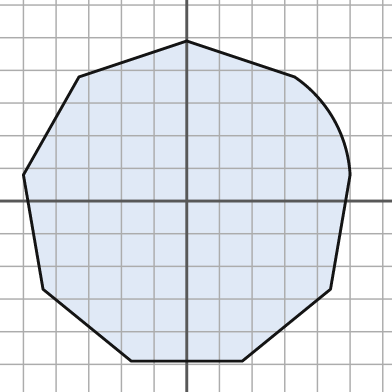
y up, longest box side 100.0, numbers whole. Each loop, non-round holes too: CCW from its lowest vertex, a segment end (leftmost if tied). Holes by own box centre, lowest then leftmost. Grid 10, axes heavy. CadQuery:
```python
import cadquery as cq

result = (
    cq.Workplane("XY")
    .moveTo(-17.0, -49.0)
    .lineTo(17.0, -49.0)
    .lineTo(44.0, -27.0)
    .lineTo(50.0, 8.0)
    .threePointArc((45.0, 25.0), (33.0, 38.0))
    .lineTo(0.0, 49.0)
    .lineTo(-33.0, 38.0)
    .lineTo(-50.0, 8.0)
    .lineTo(-44.0, -27.0)
    .close()
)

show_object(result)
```